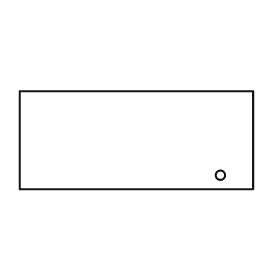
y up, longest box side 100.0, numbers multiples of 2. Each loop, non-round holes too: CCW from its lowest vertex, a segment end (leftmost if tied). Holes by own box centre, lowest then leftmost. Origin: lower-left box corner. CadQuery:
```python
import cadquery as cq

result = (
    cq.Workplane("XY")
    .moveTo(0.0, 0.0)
    .lineTo(100.0, 0.0)
    .lineTo(100.0, 42.0)
    .lineTo(0.0, 42.0)
    .close()
    .moveTo(86.0, 6.0)
    .circle(2.0)
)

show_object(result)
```